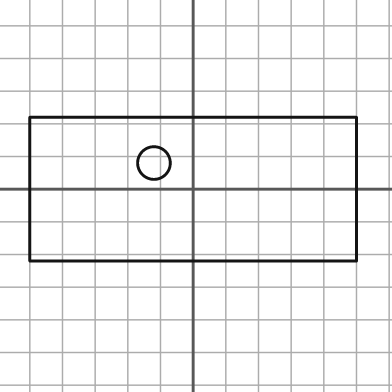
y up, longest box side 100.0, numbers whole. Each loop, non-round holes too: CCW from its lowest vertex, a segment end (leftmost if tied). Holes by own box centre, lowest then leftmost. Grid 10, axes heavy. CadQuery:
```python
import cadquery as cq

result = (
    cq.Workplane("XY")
    .moveTo(-50.0, -22.0)
    .lineTo(50.0, -22.0)
    .lineTo(50.0, 22.0)
    .lineTo(-50.0, 22.0)
    .close()
    .moveTo(-12.0, 8.0)
    .circle(5.0)
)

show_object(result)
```